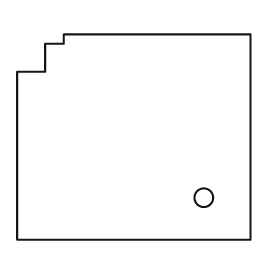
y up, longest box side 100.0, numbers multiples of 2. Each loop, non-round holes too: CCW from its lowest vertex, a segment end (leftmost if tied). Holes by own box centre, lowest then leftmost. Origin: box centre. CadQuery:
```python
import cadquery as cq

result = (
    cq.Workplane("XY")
    .moveTo(-50.0, -44.0)
    .lineTo(50.0, -44.0)
    .lineTo(50.0, 44.0)
    .lineTo(-30.0, 44.0)
    .lineTo(-30.0, 40.0)
    .lineTo(-38.0, 40.0)
    .lineTo(-38.0, 28.0)
    .lineTo(-50.0, 28.0)
    .close()
    .moveTo(30.0, -26.0)
    .circle(4.0)
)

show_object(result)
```